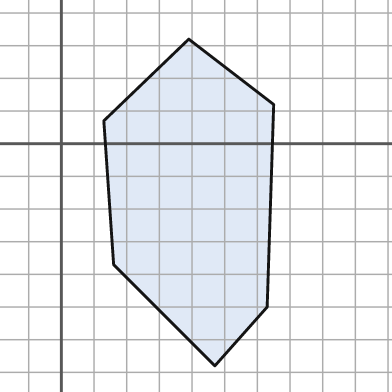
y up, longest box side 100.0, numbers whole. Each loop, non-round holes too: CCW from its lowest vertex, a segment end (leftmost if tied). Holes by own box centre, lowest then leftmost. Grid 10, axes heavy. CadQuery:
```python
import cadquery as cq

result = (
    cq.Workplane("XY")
    .moveTo(47.0, -68.0)
    .lineTo(63.0, -50.0)
    .lineTo(65.0, 12.0)
    .lineTo(39.0, 32.0)
    .lineTo(13.0, 7.0)
    .lineTo(16.0, -37.0)
    .close()
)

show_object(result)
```